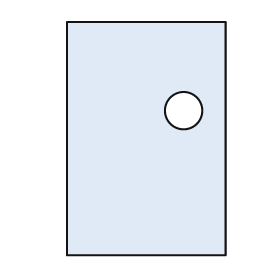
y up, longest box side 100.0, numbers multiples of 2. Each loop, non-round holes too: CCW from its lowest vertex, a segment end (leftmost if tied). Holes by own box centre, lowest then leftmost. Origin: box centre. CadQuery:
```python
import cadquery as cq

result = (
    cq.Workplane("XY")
    .moveTo(-34.0, -50.0)
    .lineTo(34.0, -50.0)
    .lineTo(34.0, 50.0)
    .lineTo(-34.0, 50.0)
    .close()
    .moveTo(16.0, 12.0)
    .circle(8.0)
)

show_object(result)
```